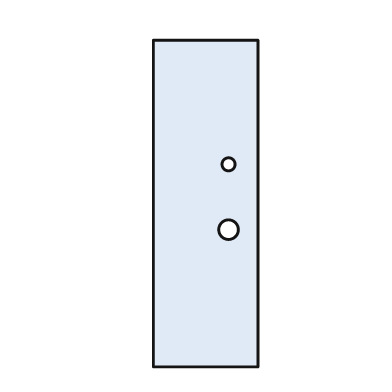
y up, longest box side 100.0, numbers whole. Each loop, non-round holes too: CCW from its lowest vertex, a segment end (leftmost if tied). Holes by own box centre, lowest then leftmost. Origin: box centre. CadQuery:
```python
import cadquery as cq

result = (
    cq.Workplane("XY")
    .moveTo(-16.0, -50.0)
    .lineTo(16.0, -50.0)
    .lineTo(16.0, 50.0)
    .lineTo(-16.0, 50.0)
    .close()
    .moveTo(7.0, -8.0)
    .circle(3.0)
    .moveTo(7.0, 12.0)
    .circle(2.0)
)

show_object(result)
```